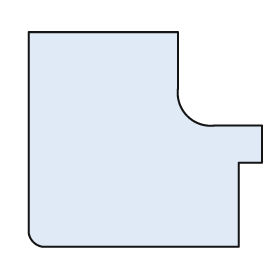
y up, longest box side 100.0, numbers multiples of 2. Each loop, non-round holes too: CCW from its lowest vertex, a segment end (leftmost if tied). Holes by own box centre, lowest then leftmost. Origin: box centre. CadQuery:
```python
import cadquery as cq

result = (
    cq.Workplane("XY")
    .moveTo(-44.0, -46.0)
    .lineTo(40.0, -46.0)
    .lineTo(40.0, -10.0)
    .lineTo(50.0, -10.0)
    .lineTo(50.0, 6.0)
    .lineTo(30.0, 6.0)
    .threePointArc((18.0, 10.0), (14.0, 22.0))
    .lineTo(14.0, 46.0)
    .lineTo(-50.0, 46.0)
    .lineTo(-50.0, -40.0)
    .threePointArc((-48.0, -44.0), (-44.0, -46.0))
    .close()
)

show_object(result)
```